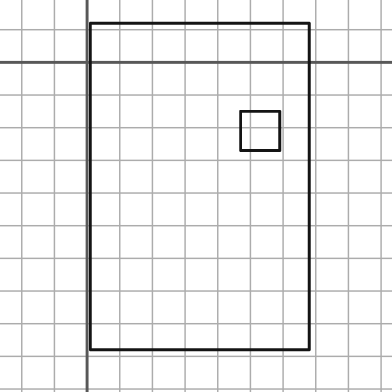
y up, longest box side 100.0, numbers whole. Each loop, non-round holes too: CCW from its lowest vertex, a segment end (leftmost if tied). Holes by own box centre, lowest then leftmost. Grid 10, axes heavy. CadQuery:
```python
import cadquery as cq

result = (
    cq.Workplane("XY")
    .moveTo(1.0, -88.0)
    .lineTo(68.0, -88.0)
    .lineTo(68.0, 12.0)
    .lineTo(1.0, 12.0)
    .close()
    .moveTo(47.0, -27.0)
    .lineTo(59.0, -27.0)
    .lineTo(59.0, -15.0)
    .lineTo(47.0, -15.0)
    .close()
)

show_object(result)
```